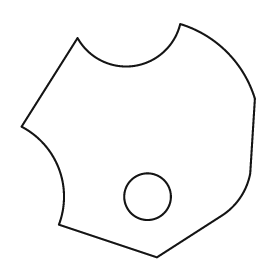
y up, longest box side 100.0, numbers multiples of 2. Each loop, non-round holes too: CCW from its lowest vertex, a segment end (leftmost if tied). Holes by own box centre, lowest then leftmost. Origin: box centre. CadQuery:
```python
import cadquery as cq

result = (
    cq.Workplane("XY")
    .moveTo(8.0, -50.0)
    .lineTo(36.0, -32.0)
    .threePointArc((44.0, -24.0), (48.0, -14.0))
    .lineTo(50.0, 18.0)
    .threePointArc((38.0, 38.0), (18.0, 50.0))
    .threePointArc((-2.0, 32.0), (-26.0, 44.0))
    .lineTo(-50.0, 6.0)
    .threePointArc((-34.0, -12.0), (-34.0, -36.0))
    .close()
    .moveTo(4.0, -24.0)
    .circle(10.0)
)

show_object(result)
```